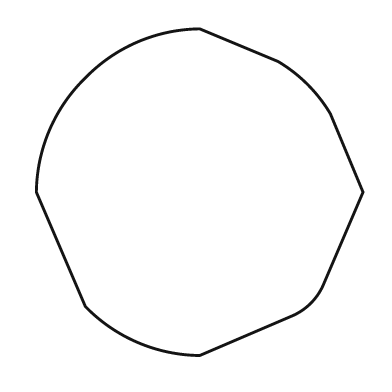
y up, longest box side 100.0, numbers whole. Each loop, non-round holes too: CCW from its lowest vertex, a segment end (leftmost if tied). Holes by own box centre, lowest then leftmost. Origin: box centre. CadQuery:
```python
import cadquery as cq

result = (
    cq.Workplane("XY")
    .moveTo(0.0, -50.0)
    .lineTo(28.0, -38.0)
    .threePointArc((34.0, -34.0), (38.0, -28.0))
    .lineTo(50.0, 0.0)
    .lineTo(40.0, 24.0)
    .threePointArc((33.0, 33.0), (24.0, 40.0))
    .lineTo(0.0, 50.0)
    .threePointArc((-19.0, 46.0), (-35.0, 35.0))
    .threePointArc((-46.0, 19.0), (-50.0, 0.0))
    .lineTo(-35.0, -35.0)
    .threePointArc((-19.0, -46.0), (0.0, -50.0))
    .close()
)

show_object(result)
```